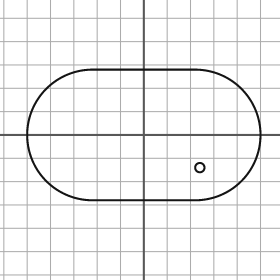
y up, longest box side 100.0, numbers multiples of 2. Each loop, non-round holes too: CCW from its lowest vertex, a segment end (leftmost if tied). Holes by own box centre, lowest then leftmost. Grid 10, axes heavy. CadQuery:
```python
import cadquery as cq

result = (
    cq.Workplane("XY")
    .moveTo(-22.0, -28.0)
    .lineTo(22.0, -28.0)
    .threePointArc((50.0, 0.0), (22.0, 28.0))
    .lineTo(-22.0, 28.0)
    .threePointArc((-50.0, 0.0), (-22.0, -28.0))
    .close()
    .moveTo(24.0, -14.0)
    .circle(2.0)
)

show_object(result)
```